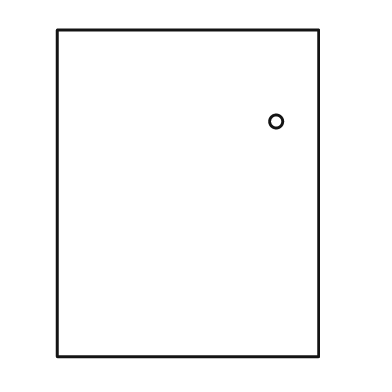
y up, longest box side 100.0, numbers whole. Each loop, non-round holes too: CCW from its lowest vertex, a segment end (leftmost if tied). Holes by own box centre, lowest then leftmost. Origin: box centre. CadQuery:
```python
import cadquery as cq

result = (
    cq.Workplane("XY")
    .moveTo(-40.0, -50.0)
    .lineTo(40.0, -50.0)
    .lineTo(40.0, 50.0)
    .lineTo(-40.0, 50.0)
    .close()
    .moveTo(27.0, 22.0)
    .circle(2.0)
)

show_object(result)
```